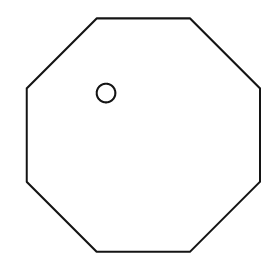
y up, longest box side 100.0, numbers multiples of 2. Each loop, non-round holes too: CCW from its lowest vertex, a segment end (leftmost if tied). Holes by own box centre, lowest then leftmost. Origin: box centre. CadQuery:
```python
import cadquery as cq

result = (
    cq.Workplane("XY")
    .moveTo(-20.0, -50.0)
    .lineTo(20.0, -50.0)
    .lineTo(50.0, -20.0)
    .lineTo(50.0, 20.0)
    .lineTo(20.0, 50.0)
    .lineTo(-20.0, 50.0)
    .lineTo(-50.0, 20.0)
    .lineTo(-50.0, -20.0)
    .close()
    .moveTo(-16.0, 18.0)
    .circle(4.0)
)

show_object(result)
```